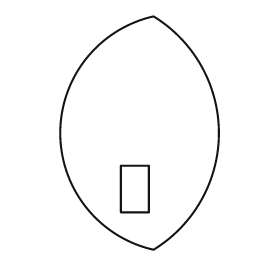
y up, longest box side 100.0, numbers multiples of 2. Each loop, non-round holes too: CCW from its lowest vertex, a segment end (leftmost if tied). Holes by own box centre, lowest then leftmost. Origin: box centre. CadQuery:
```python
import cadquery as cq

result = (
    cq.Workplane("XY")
    .moveTo(6.0, -50.0)
    .threePointArc((34.0, 0.0), (6.0, 50.0))
    .threePointArc((-34.0, 0.0), (6.0, -50.0))
    .close()
    .moveTo(-8.0, -34.0)
    .lineTo(4.0, -34.0)
    .lineTo(4.0, -14.0)
    .lineTo(-8.0, -14.0)
    .close()
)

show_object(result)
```